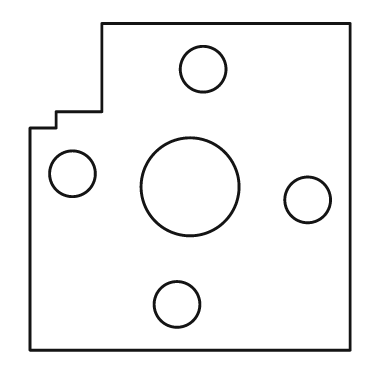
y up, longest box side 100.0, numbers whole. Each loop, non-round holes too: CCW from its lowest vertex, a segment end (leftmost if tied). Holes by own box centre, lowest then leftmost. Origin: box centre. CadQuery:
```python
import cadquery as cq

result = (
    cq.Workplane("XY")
    .moveTo(-49.0, -50.0)
    .lineTo(49.0, -50.0)
    .lineTo(49.0, 50.0)
    .lineTo(-27.0, 50.0)
    .lineTo(-27.0, 23.0)
    .lineTo(-41.0, 23.0)
    .lineTo(-41.0, 18.0)
    .lineTo(-49.0, 18.0)
    .close()
    .moveTo(-4.0, -36.0)
    .circle(7.0)
    .moveTo(36.0, -4.0)
    .circle(7.0)
    .moveTo(0.0, 0.0)
    .circle(15.0)
    .moveTo(-36.0, 4.0)
    .circle(7.0)
    .moveTo(4.0, 36.0)
    .circle(7.0)
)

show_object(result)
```